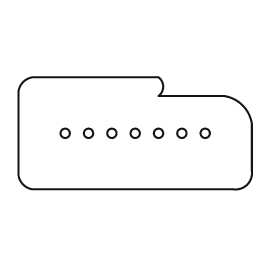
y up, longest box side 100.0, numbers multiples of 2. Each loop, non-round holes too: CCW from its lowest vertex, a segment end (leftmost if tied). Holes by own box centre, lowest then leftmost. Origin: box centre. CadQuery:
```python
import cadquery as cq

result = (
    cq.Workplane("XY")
    .moveTo(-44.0, -24.0)
    .lineTo(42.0, -24.0)
    .threePointArc((48.0, -22.0), (50.0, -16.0))
    .lineTo(50.0, 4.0)
    .threePointArc((46.0, 12.0), (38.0, 16.0))
    .lineTo(10.0, 16.0)
    .threePointArc((12.0, 20.0), (10.0, 24.0))
    .lineTo(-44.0, 24.0)
    .threePointArc((-48.0, 22.0), (-50.0, 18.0))
    .lineTo(-50.0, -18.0)
    .threePointArc((-48.0, -22.0), (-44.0, -24.0))
    .close()
    .moveTo(-30.0, 0.0)
    .circle(2.0)
    .moveTo(-20.0, 0.0)
    .circle(2.0)
    .moveTo(-10.0, 0.0)
    .circle(2.0)
    .moveTo(0.0, 0.0)
    .circle(2.0)
    .moveTo(10.0, 0.0)
    .circle(2.0)
    .moveTo(20.0, 0.0)
    .circle(2.0)
    .moveTo(30.0, 0.0)
    .circle(2.0)
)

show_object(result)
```